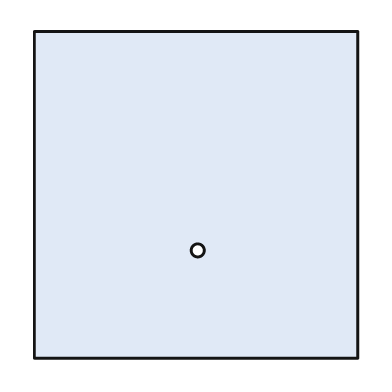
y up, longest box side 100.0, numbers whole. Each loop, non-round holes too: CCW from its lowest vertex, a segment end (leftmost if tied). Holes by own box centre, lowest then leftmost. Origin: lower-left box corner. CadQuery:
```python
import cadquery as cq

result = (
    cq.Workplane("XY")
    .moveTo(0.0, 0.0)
    .lineTo(99.0, 0.0)
    .lineTo(99.0, 100.0)
    .lineTo(0.0, 100.0)
    .close()
    .moveTo(50.0, 33.0)
    .circle(2.0)
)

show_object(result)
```